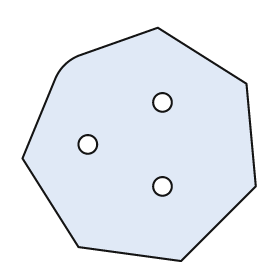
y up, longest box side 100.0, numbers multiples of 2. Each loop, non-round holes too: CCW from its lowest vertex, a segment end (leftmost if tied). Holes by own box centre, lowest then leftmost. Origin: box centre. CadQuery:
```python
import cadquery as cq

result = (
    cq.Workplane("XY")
    .moveTo(18.0, -50.0)
    .lineTo(50.0, -18.0)
    .lineTo(46.0, 26.0)
    .lineTo(8.0, 50.0)
    .lineTo(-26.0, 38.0)
    .threePointArc((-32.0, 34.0), (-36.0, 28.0))
    .lineTo(-50.0, -6.0)
    .lineTo(-26.0, -44.0)
    .close()
    .moveTo(10.0, -18.0)
    .circle(4.0)
    .moveTo(-22.0, 0.0)
    .circle(4.0)
    .moveTo(10.0, 18.0)
    .circle(4.0)
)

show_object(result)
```